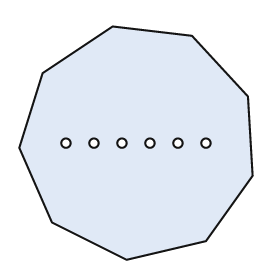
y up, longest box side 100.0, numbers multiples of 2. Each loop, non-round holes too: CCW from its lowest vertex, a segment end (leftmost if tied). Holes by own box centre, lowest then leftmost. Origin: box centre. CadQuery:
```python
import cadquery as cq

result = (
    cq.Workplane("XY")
    .moveTo(-4.0, -50.0)
    .lineTo(30.0, -42.0)
    .lineTo(50.0, -14.0)
    .lineTo(48.0, 20.0)
    .lineTo(24.0, 46.0)
    .lineTo(-10.0, 50.0)
    .lineTo(-40.0, 30.0)
    .lineTo(-50.0, -2.0)
    .lineTo(-36.0, -34.0)
    .close()
    .moveTo(-30.0, 0.0)
    .circle(2.0)
    .moveTo(-18.0, 0.0)
    .circle(2.0)
    .moveTo(-6.0, 0.0)
    .circle(2.0)
    .moveTo(6.0, 0.0)
    .circle(2.0)
    .moveTo(18.0, 0.0)
    .circle(2.0)
    .moveTo(30.0, 0.0)
    .circle(2.0)
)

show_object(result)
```